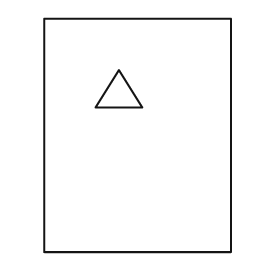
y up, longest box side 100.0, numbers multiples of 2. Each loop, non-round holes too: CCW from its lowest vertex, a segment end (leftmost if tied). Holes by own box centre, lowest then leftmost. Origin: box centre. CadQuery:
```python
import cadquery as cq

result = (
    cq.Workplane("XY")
    .moveTo(-40.0, -50.0)
    .lineTo(40.0, -50.0)
    .lineTo(40.0, 50.0)
    .lineTo(-40.0, 50.0)
    .close()
    .moveTo(-18.0, 12.0)
    .lineTo(2.0, 12.0)
    .lineTo(-8.0, 28.0)
    .close()
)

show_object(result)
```